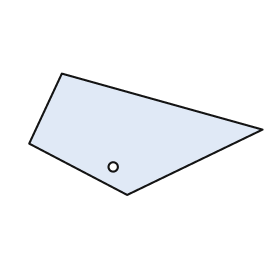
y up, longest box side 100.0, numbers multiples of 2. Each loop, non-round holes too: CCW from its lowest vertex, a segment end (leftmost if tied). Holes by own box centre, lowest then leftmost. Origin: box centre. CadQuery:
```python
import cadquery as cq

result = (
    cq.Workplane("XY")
    .moveTo(-8.0, -26.0)
    .lineTo(50.0, 2.0)
    .lineTo(-36.0, 26.0)
    .lineTo(-50.0, -4.0)
    .close()
    .moveTo(-14.0, -14.0)
    .circle(2.0)
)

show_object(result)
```